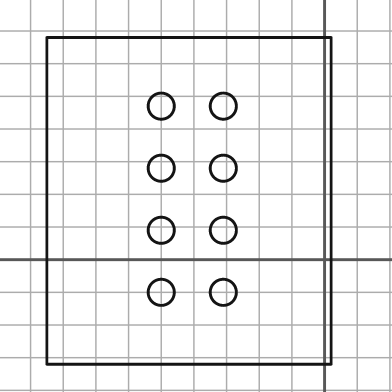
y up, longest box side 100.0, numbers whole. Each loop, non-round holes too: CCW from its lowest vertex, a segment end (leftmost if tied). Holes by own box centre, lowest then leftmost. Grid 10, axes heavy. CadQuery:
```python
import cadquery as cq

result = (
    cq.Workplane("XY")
    .moveTo(-85.0, -32.0)
    .lineTo(2.0, -32.0)
    .lineTo(2.0, 68.0)
    .lineTo(-85.0, 68.0)
    .close()
    .moveTo(-50.0, -10.0)
    .circle(4.0)
    .moveTo(-31.0, -10.0)
    .circle(4.0)
    .moveTo(-50.0, 9.0)
    .circle(4.0)
    .moveTo(-31.0, 9.0)
    .circle(4.0)
    .moveTo(-50.0, 28.0)
    .circle(4.0)
    .moveTo(-31.0, 28.0)
    .circle(4.0)
    .moveTo(-50.0, 47.0)
    .circle(4.0)
    .moveTo(-31.0, 47.0)
    .circle(4.0)
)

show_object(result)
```